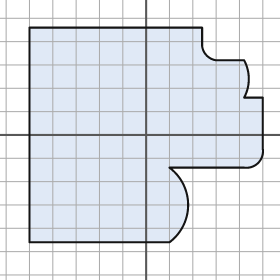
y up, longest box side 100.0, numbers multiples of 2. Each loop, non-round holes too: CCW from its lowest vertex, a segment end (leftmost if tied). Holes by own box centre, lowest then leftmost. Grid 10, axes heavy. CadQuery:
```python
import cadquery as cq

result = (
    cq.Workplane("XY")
    .moveTo(-50.0, -46.0)
    .lineTo(10.0, -46.0)
    .threePointArc((18.0, -30.0), (10.0, -14.0))
    .lineTo(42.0, -14.0)
    .threePointArc((48.0, -12.0), (50.0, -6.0))
    .lineTo(50.0, 16.0)
    .lineTo(42.0, 16.0)
    .threePointArc((44.0, 24.0), (42.0, 32.0))
    .lineTo(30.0, 32.0)
    .threePointArc((26.0, 34.0), (24.0, 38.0))
    .lineTo(24.0, 46.0)
    .lineTo(-50.0, 46.0)
    .close()
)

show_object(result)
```